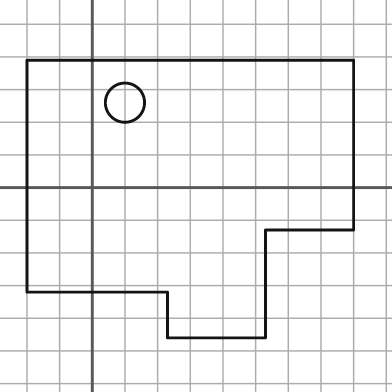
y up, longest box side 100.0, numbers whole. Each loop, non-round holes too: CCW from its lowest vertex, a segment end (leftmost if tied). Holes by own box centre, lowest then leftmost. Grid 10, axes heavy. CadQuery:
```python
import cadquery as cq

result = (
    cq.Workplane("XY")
    .moveTo(23.0, -46.0)
    .lineTo(53.0, -46.0)
    .lineTo(53.0, -13.0)
    .lineTo(80.0, -13.0)
    .lineTo(80.0, 39.0)
    .lineTo(-20.0, 39.0)
    .lineTo(-20.0, -32.0)
    .lineTo(23.0, -32.0)
    .close()
    .moveTo(10.0, 26.0)
    .circle(6.0)
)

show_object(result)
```